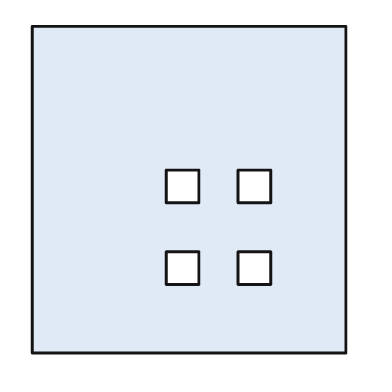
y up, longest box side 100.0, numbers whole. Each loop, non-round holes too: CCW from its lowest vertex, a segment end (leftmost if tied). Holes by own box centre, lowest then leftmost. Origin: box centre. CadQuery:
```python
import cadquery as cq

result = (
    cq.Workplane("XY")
    .moveTo(-48.0, -50.0)
    .lineTo(48.0, -50.0)
    .lineTo(48.0, 50.0)
    .lineTo(-48.0, 50.0)
    .close()
    .moveTo(-7.0, -29.0)
    .lineTo(3.0, -29.0)
    .lineTo(3.0, -19.0)
    .lineTo(-7.0, -19.0)
    .close()
    .moveTo(15.0, -29.0)
    .lineTo(25.0, -29.0)
    .lineTo(25.0, -19.0)
    .lineTo(15.0, -19.0)
    .close()
    .moveTo(-7.0, -4.0)
    .lineTo(3.0, -4.0)
    .lineTo(3.0, 6.0)
    .lineTo(-7.0, 6.0)
    .close()
    .moveTo(15.0, -4.0)
    .lineTo(25.0, -4.0)
    .lineTo(25.0, 6.0)
    .lineTo(15.0, 6.0)
    .close()
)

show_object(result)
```